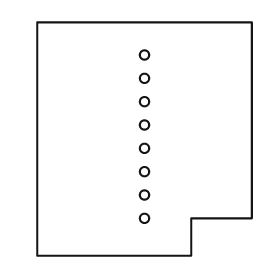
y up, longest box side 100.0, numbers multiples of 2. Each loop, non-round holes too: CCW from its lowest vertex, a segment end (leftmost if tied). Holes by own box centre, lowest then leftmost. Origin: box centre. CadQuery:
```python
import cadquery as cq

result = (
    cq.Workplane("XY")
    .moveTo(-46.0, -50.0)
    .lineTo(20.0, -50.0)
    .lineTo(20.0, -34.0)
    .lineTo(46.0, -34.0)
    .lineTo(46.0, 50.0)
    .lineTo(-46.0, 50.0)
    .close()
    .moveTo(0.0, -34.0)
    .circle(2.0)
    .moveTo(0.0, -24.0)
    .circle(2.0)
    .moveTo(0.0, -14.0)
    .circle(2.0)
    .moveTo(0.0, -4.0)
    .circle(2.0)
    .moveTo(0.0, 6.0)
    .circle(2.0)
    .moveTo(0.0, 16.0)
    .circle(2.0)
    .moveTo(0.0, 26.0)
    .circle(2.0)
    .moveTo(0.0, 36.0)
    .circle(2.0)
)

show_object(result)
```